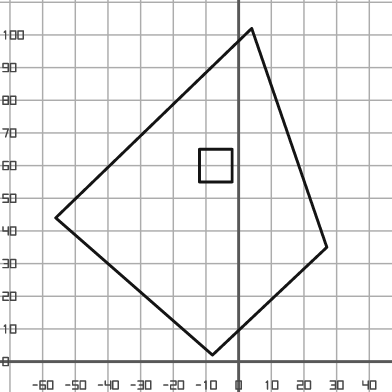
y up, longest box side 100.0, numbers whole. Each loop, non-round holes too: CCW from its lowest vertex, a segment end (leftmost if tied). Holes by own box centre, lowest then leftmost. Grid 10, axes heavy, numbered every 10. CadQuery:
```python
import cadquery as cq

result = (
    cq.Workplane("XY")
    .moveTo(-8.0, 2.0)
    .lineTo(27.0, 35.0)
    .lineTo(4.0, 102.0)
    .lineTo(-56.0, 44.0)
    .close()
    .moveTo(-12.0, 55.0)
    .lineTo(-2.0, 55.0)
    .lineTo(-2.0, 65.0)
    .lineTo(-12.0, 65.0)
    .close()
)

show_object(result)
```